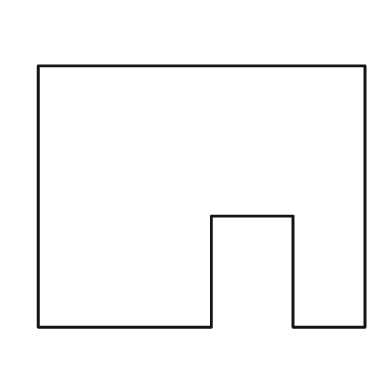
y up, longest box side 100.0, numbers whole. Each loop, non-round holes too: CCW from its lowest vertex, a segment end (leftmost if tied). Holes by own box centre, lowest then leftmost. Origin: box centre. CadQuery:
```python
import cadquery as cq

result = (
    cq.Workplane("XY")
    .moveTo(-50.0, -40.0)
    .lineTo(3.0, -40.0)
    .lineTo(3.0, -6.0)
    .lineTo(28.0, -6.0)
    .lineTo(28.0, -40.0)
    .lineTo(50.0, -40.0)
    .lineTo(50.0, 40.0)
    .lineTo(-50.0, 40.0)
    .close()
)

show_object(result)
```